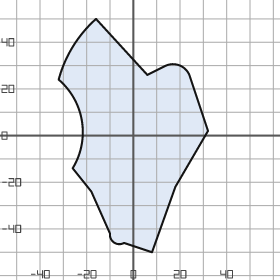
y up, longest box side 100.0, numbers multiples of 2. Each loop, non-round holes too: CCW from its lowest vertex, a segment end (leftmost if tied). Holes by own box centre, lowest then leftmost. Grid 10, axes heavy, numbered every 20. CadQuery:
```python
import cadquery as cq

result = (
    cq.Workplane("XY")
    .moveTo(8.0, -50.0)
    .lineTo(18.0, -22.0)
    .lineTo(32.0, 2.0)
    .lineTo(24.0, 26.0)
    .threePointArc((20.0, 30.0), (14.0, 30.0))
    .lineTo(6.0, 26.0)
    .lineTo(-16.0, 50.0)
    .threePointArc((-26.0, 38.0), (-32.0, 24.0))
    .threePointArc((-22.0, 6.0), (-26.0, -14.0))
    .lineTo(-18.0, -24.0)
    .lineTo(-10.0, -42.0)
    .threePointArc((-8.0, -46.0), (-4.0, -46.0))
    .close()
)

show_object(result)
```